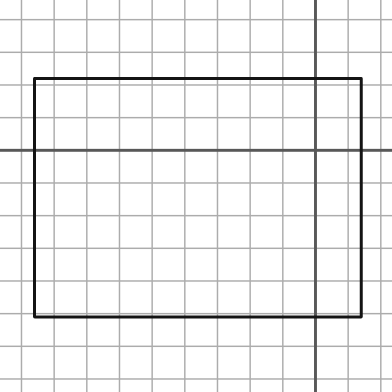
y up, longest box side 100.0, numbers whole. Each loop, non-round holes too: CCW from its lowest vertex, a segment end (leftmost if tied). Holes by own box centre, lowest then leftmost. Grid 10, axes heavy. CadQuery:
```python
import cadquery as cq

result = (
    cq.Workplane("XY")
    .moveTo(-86.0, -51.0)
    .lineTo(14.0, -51.0)
    .lineTo(14.0, 22.0)
    .lineTo(-86.0, 22.0)
    .close()
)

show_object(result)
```